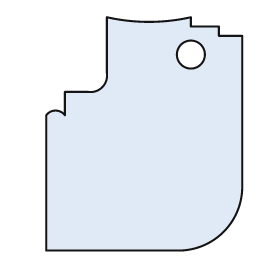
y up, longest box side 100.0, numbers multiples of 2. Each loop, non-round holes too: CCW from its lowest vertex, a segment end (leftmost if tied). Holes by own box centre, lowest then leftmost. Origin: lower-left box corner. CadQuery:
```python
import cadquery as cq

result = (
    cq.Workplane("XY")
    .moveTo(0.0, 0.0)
    .lineTo(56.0, 0.0)
    .threePointArc((76.0, 8.0), (84.0, 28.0))
    .lineTo(84.0, 92.0)
    .lineTo(74.0, 92.0)
    .lineTo(74.0, 96.0)
    .lineTo(62.0, 96.0)
    .lineTo(62.0, 100.0)
    .threePointArc((44.0, 98.0), (26.0, 100.0))
    .lineTo(26.0, 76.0)
    .threePointArc((24.0, 70.0), (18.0, 68.0))
    .lineTo(8.0, 68.0)
    .lineTo(8.0, 58.0)
    .threePointArc((4.0, 60.0), (0.0, 58.0))
    .close()
    .moveTo(62.0, 84.0)
    .circle(6.0)
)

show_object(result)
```